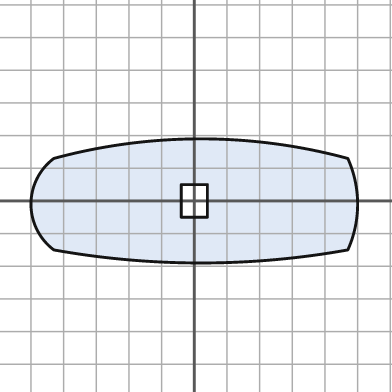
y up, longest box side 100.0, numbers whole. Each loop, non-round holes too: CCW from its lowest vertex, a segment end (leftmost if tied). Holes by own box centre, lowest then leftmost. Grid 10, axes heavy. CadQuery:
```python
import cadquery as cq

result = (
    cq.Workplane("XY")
    .moveTo(-43.0, -15.0)
    .threePointArc((2.0, -19.0), (47.0, -15.0))
    .threePointArc((50.0, -1.0), (47.0, 13.0))
    .threePointArc((2.0, 19.0), (-43.0, 13.0))
    .threePointArc((-50.0, -1.0), (-43.0, -15.0))
    .close()
    .moveTo(-4.0, -5.0)
    .lineTo(4.0, -5.0)
    .lineTo(4.0, 5.0)
    .lineTo(-4.0, 5.0)
    .close()
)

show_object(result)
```